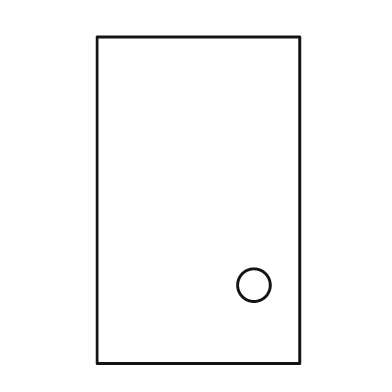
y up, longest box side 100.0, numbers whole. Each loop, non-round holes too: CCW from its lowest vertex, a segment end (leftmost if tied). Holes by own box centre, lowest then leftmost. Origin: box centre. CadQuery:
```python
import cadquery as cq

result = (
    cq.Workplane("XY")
    .moveTo(-31.0, -50.0)
    .lineTo(31.0, -50.0)
    .lineTo(31.0, 50.0)
    .lineTo(-31.0, 50.0)
    .close()
    .moveTo(17.0, -26.0)
    .circle(5.0)
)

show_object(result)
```